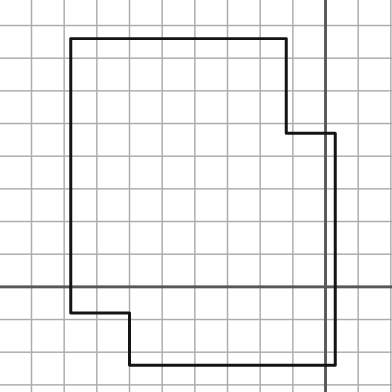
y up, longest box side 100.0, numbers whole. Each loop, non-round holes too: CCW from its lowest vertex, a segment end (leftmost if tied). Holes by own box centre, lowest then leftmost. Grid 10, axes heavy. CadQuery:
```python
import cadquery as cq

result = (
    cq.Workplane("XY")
    .moveTo(-60.0, -24.0)
    .lineTo(3.0, -24.0)
    .lineTo(3.0, 47.0)
    .lineTo(-12.0, 47.0)
    .lineTo(-12.0, 76.0)
    .lineTo(-78.0, 76.0)
    .lineTo(-78.0, -8.0)
    .lineTo(-60.0, -8.0)
    .close()
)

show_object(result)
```